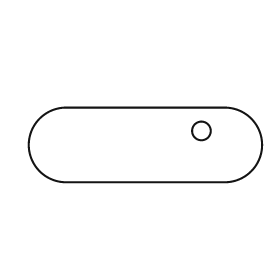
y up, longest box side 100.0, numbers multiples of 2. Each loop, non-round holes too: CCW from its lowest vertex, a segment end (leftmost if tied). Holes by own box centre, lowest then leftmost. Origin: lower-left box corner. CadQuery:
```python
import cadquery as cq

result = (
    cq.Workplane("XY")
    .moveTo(16.0, 0.0)
    .lineTo(84.0, 0.0)
    .threePointArc((100.0, 16.0), (84.0, 32.0))
    .lineTo(16.0, 32.0)
    .threePointArc((0.0, 16.0), (16.0, 0.0))
    .close()
    .moveTo(74.0, 22.0)
    .circle(4.0)
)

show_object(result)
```